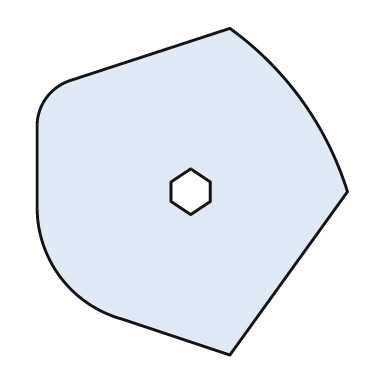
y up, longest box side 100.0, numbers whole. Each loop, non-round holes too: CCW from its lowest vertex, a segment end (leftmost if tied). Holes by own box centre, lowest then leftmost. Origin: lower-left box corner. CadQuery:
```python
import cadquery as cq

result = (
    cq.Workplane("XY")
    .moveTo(59.0, 0.0)
    .lineTo(95.0, 50.0)
    .threePointArc((81.0, 78.0), (59.0, 100.0))
    .lineTo(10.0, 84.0)
    .threePointArc((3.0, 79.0), (0.0, 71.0))
    .lineTo(0.0, 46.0)
    .threePointArc((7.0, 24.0), (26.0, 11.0))
    .close()
    .moveTo(47.0, 43.0)
    .lineTo(53.0, 47.0)
    .lineTo(53.0, 53.0)
    .lineTo(47.0, 57.0)
    .lineTo(41.0, 53.0)
    .lineTo(41.0, 47.0)
    .close()
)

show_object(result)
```